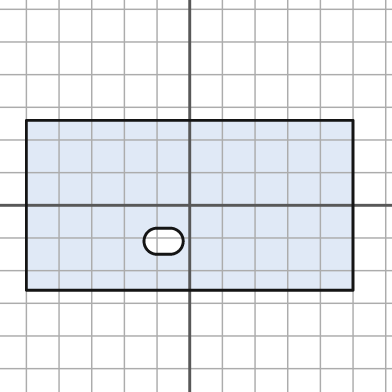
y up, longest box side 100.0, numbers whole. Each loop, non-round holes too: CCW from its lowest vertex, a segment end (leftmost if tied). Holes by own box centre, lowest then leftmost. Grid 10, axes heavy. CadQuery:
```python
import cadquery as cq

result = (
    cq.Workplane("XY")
    .moveTo(-50.0, -26.0)
    .lineTo(50.0, -26.0)
    .lineTo(50.0, 26.0)
    .lineTo(-50.0, 26.0)
    .close()
    .moveTo(-10.0, -15.0)
    .lineTo(-6.0, -15.0)
    .threePointArc((-2.0, -11.0), (-6.0, -7.0))
    .lineTo(-10.0, -7.0)
    .threePointArc((-14.0, -11.0), (-10.0, -15.0))
    .close()
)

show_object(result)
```